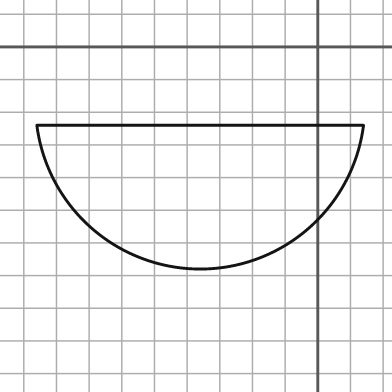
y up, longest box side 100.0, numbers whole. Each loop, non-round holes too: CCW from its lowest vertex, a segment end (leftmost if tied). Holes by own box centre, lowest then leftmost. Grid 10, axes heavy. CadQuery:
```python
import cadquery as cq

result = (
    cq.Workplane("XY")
    .moveTo(-86.0, -24.0)
    .threePointArc((-36.0, -68.0), (14.0, -24.0))
    .close()
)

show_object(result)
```